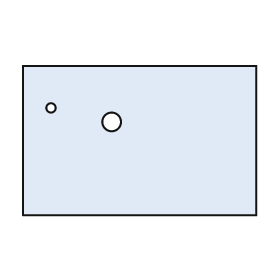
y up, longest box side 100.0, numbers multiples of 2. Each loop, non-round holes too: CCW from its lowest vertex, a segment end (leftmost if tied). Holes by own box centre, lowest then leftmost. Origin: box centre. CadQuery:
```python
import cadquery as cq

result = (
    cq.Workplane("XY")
    .moveTo(-50.0, -32.0)
    .lineTo(50.0, -32.0)
    .lineTo(50.0, 32.0)
    .lineTo(-50.0, 32.0)
    .close()
    .moveTo(-12.0, 8.0)
    .circle(4.0)
    .moveTo(-38.0, 14.0)
    .circle(2.0)
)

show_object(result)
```